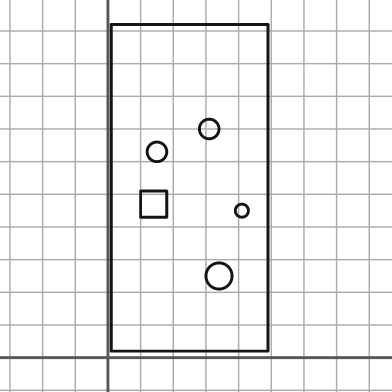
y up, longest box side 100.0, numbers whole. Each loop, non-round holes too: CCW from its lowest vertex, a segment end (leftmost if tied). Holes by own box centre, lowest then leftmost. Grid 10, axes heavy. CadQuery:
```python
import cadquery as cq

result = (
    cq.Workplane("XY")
    .moveTo(1.0, 2.0)
    .lineTo(49.0, 2.0)
    .lineTo(49.0, 102.0)
    .lineTo(1.0, 102.0)
    .close()
    .moveTo(34.0, 25.0)
    .circle(4.0)
    .moveTo(41.0, 45.0)
    .circle(2.0)
    .moveTo(10.0, 43.0)
    .lineTo(18.0, 43.0)
    .lineTo(18.0, 51.0)
    .lineTo(10.0, 51.0)
    .close()
    .moveTo(15.0, 63.0)
    .circle(3.0)
    .moveTo(31.0, 70.0)
    .circle(3.0)
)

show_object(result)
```